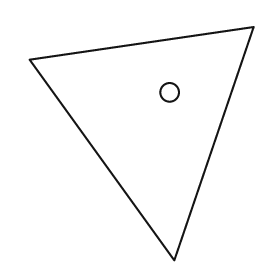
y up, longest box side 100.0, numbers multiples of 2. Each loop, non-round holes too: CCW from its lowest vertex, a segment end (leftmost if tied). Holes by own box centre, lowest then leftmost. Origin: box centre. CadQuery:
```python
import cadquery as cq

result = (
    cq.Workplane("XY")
    .moveTo(14.0, -50.0)
    .lineTo(48.0, 50.0)
    .lineTo(-48.0, 36.0)
    .close()
    .moveTo(12.0, 22.0)
    .circle(4.0)
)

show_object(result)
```